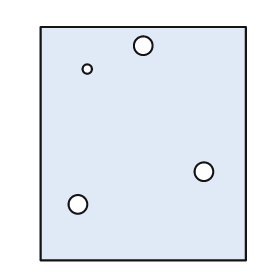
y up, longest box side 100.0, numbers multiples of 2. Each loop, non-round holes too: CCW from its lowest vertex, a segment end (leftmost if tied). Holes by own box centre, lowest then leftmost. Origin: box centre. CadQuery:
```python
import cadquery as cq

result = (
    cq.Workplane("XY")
    .moveTo(-44.0, -50.0)
    .lineTo(44.0, -50.0)
    .lineTo(44.0, 50.0)
    .lineTo(-44.0, 50.0)
    .close()
    .moveTo(-28.0, -26.0)
    .circle(4.0)
    .moveTo(26.0, -12.0)
    .circle(4.0)
    .moveTo(-24.0, 32.0)
    .circle(2.0)
    .moveTo(0.0, 42.0)
    .circle(4.0)
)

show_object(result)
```